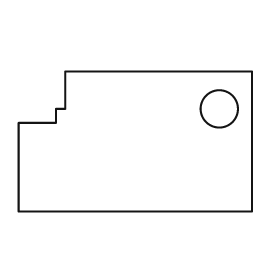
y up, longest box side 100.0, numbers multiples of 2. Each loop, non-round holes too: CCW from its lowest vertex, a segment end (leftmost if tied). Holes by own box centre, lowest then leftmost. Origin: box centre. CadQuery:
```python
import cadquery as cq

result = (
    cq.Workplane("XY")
    .moveTo(-50.0, -30.0)
    .lineTo(50.0, -30.0)
    .lineTo(50.0, 30.0)
    .lineTo(-30.0, 30.0)
    .lineTo(-30.0, 14.0)
    .lineTo(-34.0, 14.0)
    .lineTo(-34.0, 8.0)
    .lineTo(-50.0, 8.0)
    .close()
    .moveTo(36.0, 14.0)
    .circle(8.0)
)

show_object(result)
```